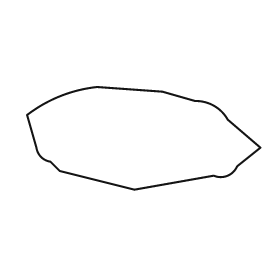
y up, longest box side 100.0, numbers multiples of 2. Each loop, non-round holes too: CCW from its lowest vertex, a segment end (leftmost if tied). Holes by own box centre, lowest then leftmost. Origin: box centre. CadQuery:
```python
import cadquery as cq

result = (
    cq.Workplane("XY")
    .moveTo(-4.0, -22.0)
    .lineTo(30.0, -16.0)
    .threePointArc((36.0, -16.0), (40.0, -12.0))
    .lineTo(50.0, -4.0)
    .lineTo(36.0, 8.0)
    .threePointArc((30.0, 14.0), (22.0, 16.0))
    .lineTo(8.0, 20.0)
    .lineTo(-20.0, 22.0)
    .threePointArc((-36.0, 18.0), (-50.0, 10.0))
    .lineTo(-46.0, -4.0)
    .threePointArc((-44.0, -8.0), (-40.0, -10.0))
    .lineTo(-36.0, -14.0)
    .close()
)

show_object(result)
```